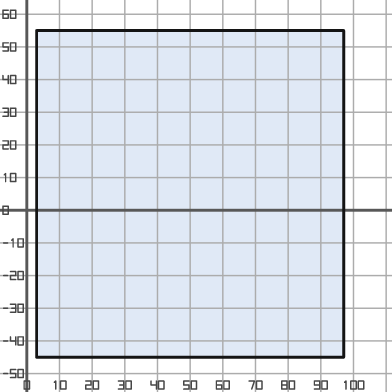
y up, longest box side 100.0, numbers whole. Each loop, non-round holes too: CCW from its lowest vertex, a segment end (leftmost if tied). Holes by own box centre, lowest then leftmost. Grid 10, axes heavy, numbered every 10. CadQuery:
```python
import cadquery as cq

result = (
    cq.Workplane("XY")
    .moveTo(3.0, -45.0)
    .lineTo(97.0, -45.0)
    .lineTo(97.0, 55.0)
    .lineTo(3.0, 55.0)
    .close()
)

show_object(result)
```